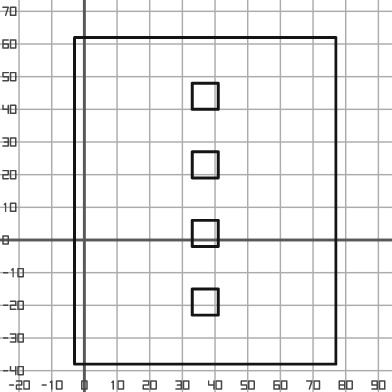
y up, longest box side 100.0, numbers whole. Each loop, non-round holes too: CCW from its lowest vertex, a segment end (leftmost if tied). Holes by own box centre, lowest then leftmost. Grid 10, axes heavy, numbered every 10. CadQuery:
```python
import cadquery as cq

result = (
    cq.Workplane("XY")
    .moveTo(-3.0, -38.0)
    .lineTo(77.0, -38.0)
    .lineTo(77.0, 62.0)
    .lineTo(-3.0, 62.0)
    .close()
    .moveTo(33.0, -23.0)
    .lineTo(41.0, -23.0)
    .lineTo(41.0, -15.0)
    .lineTo(33.0, -15.0)
    .close()
    .moveTo(33.0, -2.0)
    .lineTo(41.0, -2.0)
    .lineTo(41.0, 6.0)
    .lineTo(33.0, 6.0)
    .close()
    .moveTo(33.0, 19.0)
    .lineTo(41.0, 19.0)
    .lineTo(41.0, 27.0)
    .lineTo(33.0, 27.0)
    .close()
    .moveTo(33.0, 40.0)
    .lineTo(41.0, 40.0)
    .lineTo(41.0, 48.0)
    .lineTo(33.0, 48.0)
    .close()
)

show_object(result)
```